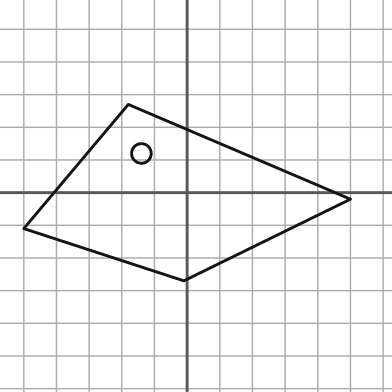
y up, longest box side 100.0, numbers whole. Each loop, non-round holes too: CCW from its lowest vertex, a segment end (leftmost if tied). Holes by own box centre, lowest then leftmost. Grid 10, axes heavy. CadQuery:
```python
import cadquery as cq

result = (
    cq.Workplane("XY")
    .moveTo(-1.0, -27.0)
    .lineTo(50.0, -2.0)
    .lineTo(-18.0, 27.0)
    .lineTo(-50.0, -11.0)
    .close()
    .moveTo(-14.0, 12.0)
    .circle(3.0)
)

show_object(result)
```